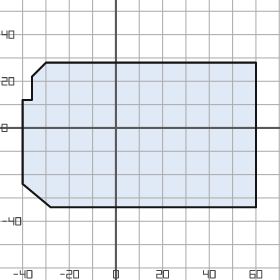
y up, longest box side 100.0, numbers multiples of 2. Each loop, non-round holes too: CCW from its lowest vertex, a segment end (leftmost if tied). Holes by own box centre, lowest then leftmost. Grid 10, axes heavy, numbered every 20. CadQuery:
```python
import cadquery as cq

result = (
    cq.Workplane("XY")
    .moveTo(-28.0, -34.0)
    .lineTo(60.0, -34.0)
    .lineTo(60.0, 28.0)
    .lineTo(-30.0, 28.0)
    .lineTo(-36.0, 22.0)
    .lineTo(-36.0, 12.0)
    .lineTo(-40.0, 12.0)
    .lineTo(-40.0, -24.0)
    .close()
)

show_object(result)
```